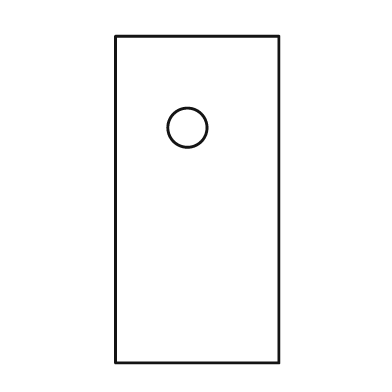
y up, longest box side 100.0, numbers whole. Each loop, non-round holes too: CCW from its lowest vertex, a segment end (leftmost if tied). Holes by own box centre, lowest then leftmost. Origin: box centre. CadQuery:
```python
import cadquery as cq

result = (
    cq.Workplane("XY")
    .moveTo(-25.0, -50.0)
    .lineTo(25.0, -50.0)
    .lineTo(25.0, 50.0)
    .lineTo(-25.0, 50.0)
    .close()
    .moveTo(-3.0, 22.0)
    .circle(6.0)
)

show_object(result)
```